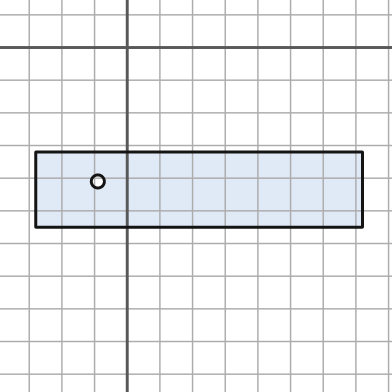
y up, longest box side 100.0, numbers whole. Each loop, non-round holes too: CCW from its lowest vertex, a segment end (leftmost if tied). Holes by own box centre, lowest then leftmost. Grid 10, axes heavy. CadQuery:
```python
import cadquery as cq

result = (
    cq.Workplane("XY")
    .moveTo(-28.0, -55.0)
    .lineTo(72.0, -55.0)
    .lineTo(72.0, -32.0)
    .lineTo(-28.0, -32.0)
    .close()
    .moveTo(-9.0, -41.0)
    .circle(2.0)
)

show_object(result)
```